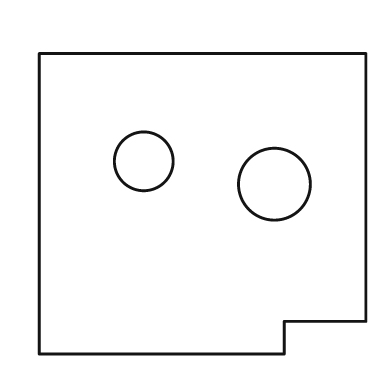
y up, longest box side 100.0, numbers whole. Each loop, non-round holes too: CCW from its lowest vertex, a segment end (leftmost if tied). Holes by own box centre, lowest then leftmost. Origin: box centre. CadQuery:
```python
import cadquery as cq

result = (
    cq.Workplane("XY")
    .moveTo(-50.0, -46.0)
    .lineTo(25.0, -46.0)
    .lineTo(25.0, -36.0)
    .lineTo(50.0, -36.0)
    .lineTo(50.0, 46.0)
    .lineTo(-50.0, 46.0)
    .close()
    .moveTo(22.0, 6.0)
    .circle(11.0)
    .moveTo(-18.0, 13.0)
    .circle(9.0)
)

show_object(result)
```